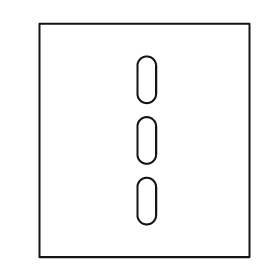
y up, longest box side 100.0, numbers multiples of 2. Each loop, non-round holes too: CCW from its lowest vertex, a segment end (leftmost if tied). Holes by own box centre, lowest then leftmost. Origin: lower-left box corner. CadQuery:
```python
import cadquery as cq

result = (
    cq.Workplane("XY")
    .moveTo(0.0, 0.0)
    .lineTo(90.0, 0.0)
    .lineTo(90.0, 100.0)
    .lineTo(0.0, 100.0)
    .close()
    .moveTo(42.0, 18.0)
    .threePointArc((46.0, 14.0), (50.0, 18.0))
    .lineTo(50.0, 30.0)
    .threePointArc((46.0, 34.0), (42.0, 30.0))
    .close()
    .moveTo(42.0, 44.0)
    .threePointArc((46.0, 40.0), (50.0, 44.0))
    .lineTo(50.0, 56.0)
    .threePointArc((46.0, 60.0), (42.0, 56.0))
    .close()
    .moveTo(42.0, 70.0)
    .threePointArc((46.0, 66.0), (50.0, 70.0))
    .lineTo(50.0, 82.0)
    .threePointArc((46.0, 86.0), (42.0, 82.0))
    .close()
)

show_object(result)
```